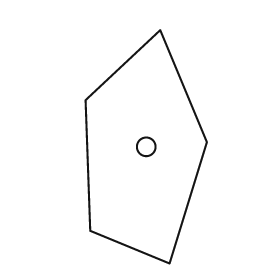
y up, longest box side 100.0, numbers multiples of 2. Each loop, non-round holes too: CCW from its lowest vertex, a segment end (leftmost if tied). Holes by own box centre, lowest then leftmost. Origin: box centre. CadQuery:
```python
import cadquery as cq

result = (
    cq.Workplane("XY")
    .moveTo(10.0, -50.0)
    .lineTo(26.0, 2.0)
    .lineTo(6.0, 50.0)
    .lineTo(-26.0, 20.0)
    .lineTo(-24.0, -36.0)
    .close()
    .moveTo(0.0, 0.0)
    .circle(4.0)
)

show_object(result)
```